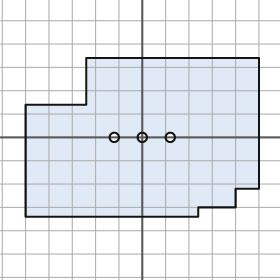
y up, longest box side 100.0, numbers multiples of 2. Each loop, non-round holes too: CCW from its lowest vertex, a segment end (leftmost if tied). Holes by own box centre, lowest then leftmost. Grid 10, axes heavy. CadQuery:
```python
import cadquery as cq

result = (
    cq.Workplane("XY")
    .moveTo(-50.0, -34.0)
    .lineTo(24.0, -34.0)
    .lineTo(24.0, -30.0)
    .lineTo(40.0, -30.0)
    .lineTo(40.0, -22.0)
    .lineTo(50.0, -22.0)
    .lineTo(50.0, 34.0)
    .lineTo(-24.0, 34.0)
    .lineTo(-24.0, 14.0)
    .lineTo(-50.0, 14.0)
    .close()
    .moveTo(-12.0, 0.0)
    .circle(2.0)
    .moveTo(0.0, 0.0)
    .circle(2.0)
    .moveTo(12.0, 0.0)
    .circle(2.0)
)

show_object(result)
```